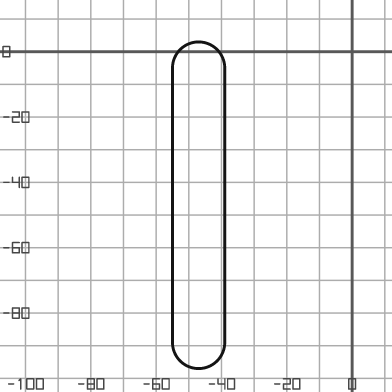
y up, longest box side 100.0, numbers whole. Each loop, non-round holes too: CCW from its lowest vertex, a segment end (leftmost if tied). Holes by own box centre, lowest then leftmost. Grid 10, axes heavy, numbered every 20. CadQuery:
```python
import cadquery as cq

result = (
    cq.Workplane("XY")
    .moveTo(-55.0, -89.0)
    .threePointArc((-47.0, -97.0), (-39.0, -89.0))
    .lineTo(-39.0, -5.0)
    .threePointArc((-47.0, 3.0), (-55.0, -5.0))
    .close()
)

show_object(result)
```